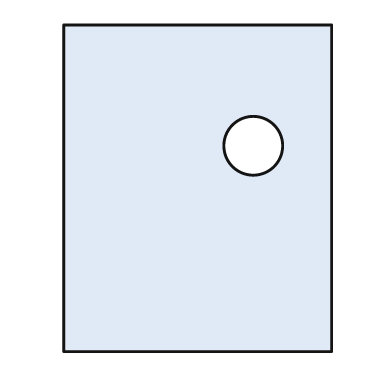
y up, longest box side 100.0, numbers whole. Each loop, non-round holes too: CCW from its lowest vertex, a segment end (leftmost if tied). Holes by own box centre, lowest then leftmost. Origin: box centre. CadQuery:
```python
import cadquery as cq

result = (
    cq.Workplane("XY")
    .moveTo(-41.0, -50.0)
    .lineTo(41.0, -50.0)
    .lineTo(41.0, 50.0)
    .lineTo(-41.0, 50.0)
    .close()
    .moveTo(17.0, 13.0)
    .circle(9.0)
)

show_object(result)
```